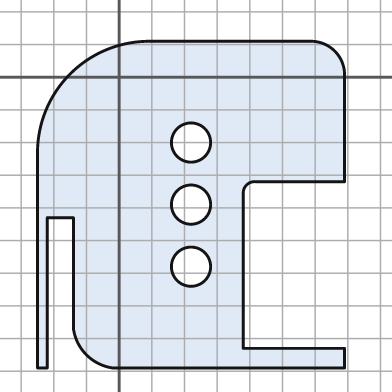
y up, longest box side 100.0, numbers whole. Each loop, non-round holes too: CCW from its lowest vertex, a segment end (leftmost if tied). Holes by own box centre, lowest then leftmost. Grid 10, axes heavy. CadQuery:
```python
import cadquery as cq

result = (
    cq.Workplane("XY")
    .moveTo(-25.0, -89.0)
    .lineTo(-22.0, -89.0)
    .lineTo(-22.0, -43.0)
    .lineTo(-14.0, -43.0)
    .lineTo(-14.0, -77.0)
    .threePointArc((-10.0, -85.0), (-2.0, -89.0))
    .lineTo(69.0, -89.0)
    .lineTo(69.0, -83.0)
    .lineTo(38.0, -83.0)
    .lineTo(38.0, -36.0)
    .threePointArc((39.0, -33.0), (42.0, -32.0))
    .lineTo(69.0, -32.0)
    .lineTo(69.0, 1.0)
    .threePointArc((66.0, 8.0), (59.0, 11.0))
    .lineTo(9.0, 11.0)
    .threePointArc((-15.0, 1.0), (-25.0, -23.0))
    .close()
    .moveTo(22.0, -58.0)
    .circle(6.0)
    .moveTo(22.0, -39.0)
    .circle(6.0)
    .moveTo(22.0, -20.0)
    .circle(6.0)
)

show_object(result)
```